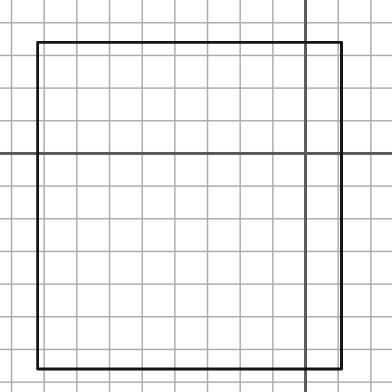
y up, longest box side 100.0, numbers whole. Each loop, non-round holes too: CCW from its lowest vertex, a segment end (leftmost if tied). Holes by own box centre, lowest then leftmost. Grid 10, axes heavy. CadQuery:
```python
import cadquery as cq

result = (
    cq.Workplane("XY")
    .moveTo(-82.0, -66.0)
    .lineTo(11.0, -66.0)
    .lineTo(11.0, 34.0)
    .lineTo(-82.0, 34.0)
    .close()
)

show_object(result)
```